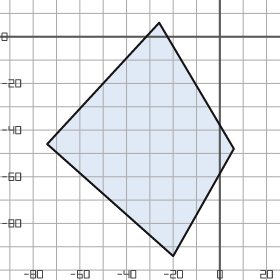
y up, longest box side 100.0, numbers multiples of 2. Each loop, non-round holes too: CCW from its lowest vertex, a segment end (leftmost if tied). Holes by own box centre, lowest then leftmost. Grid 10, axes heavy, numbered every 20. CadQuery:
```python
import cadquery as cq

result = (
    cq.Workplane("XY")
    .moveTo(-20.0, -94.0)
    .lineTo(6.0, -48.0)
    .lineTo(-26.0, 6.0)
    .lineTo(-74.0, -46.0)
    .close()
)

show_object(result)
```